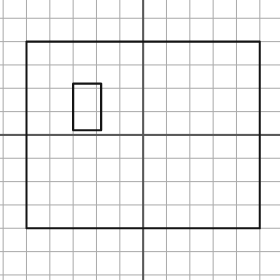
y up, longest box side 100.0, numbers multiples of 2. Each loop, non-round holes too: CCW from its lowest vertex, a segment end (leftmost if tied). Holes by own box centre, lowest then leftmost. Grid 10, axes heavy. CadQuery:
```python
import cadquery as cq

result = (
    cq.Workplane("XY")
    .moveTo(-50.0, -40.0)
    .lineTo(50.0, -40.0)
    .lineTo(50.0, 40.0)
    .lineTo(-50.0, 40.0)
    .close()
    .moveTo(-30.0, 2.0)
    .lineTo(-18.0, 2.0)
    .lineTo(-18.0, 22.0)
    .lineTo(-30.0, 22.0)
    .close()
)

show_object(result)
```